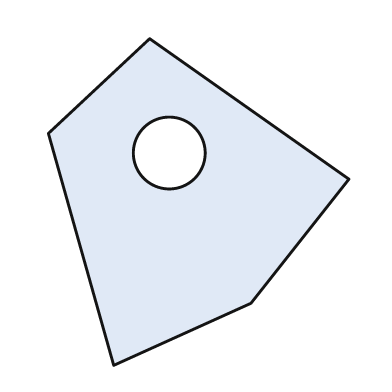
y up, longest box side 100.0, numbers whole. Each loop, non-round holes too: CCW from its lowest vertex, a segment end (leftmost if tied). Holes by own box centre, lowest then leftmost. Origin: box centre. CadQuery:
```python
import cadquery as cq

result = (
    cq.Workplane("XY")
    .moveTo(-26.0, -50.0)
    .lineTo(16.0, -31.0)
    .lineTo(46.0, 7.0)
    .lineTo(-15.0, 50.0)
    .lineTo(-46.0, 21.0)
    .close()
    .moveTo(-9.0, 15.0)
    .circle(11.0)
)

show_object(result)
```